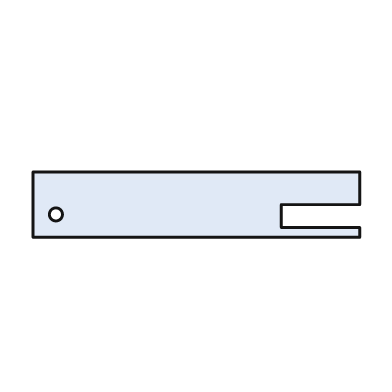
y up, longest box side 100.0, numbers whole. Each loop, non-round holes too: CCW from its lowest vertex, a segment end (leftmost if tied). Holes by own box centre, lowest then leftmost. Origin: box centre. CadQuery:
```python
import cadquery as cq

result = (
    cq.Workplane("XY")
    .moveTo(-50.0, -10.0)
    .lineTo(50.0, -10.0)
    .lineTo(50.0, -7.0)
    .lineTo(26.0, -7.0)
    .lineTo(26.0, 0.0)
    .lineTo(50.0, 0.0)
    .lineTo(50.0, 10.0)
    .lineTo(-50.0, 10.0)
    .close()
    .moveTo(-43.0, -3.0)
    .circle(2.0)
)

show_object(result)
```